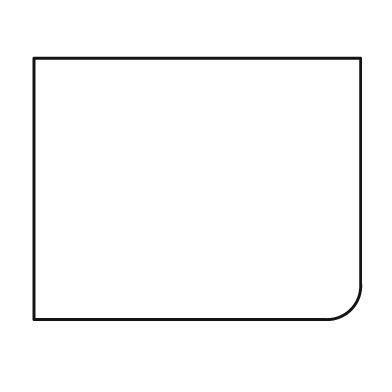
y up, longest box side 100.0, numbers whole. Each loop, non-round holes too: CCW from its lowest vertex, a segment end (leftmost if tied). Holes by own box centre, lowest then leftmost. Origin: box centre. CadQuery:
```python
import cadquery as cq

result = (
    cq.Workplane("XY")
    .moveTo(-50.0, -40.0)
    .lineTo(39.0, -40.0)
    .threePointArc((47.0, -37.0), (50.0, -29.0))
    .lineTo(50.0, 40.0)
    .lineTo(-50.0, 40.0)
    .close()
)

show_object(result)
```